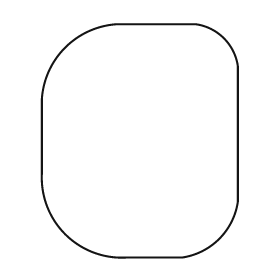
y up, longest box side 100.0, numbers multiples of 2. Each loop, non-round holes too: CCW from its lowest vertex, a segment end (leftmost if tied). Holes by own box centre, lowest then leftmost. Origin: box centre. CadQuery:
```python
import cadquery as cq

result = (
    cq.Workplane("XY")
    .moveTo(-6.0, -50.0)
    .lineTo(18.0, -50.0)
    .threePointArc((34.0, -42.0), (42.0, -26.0))
    .lineTo(42.0, 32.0)
    .threePointArc((36.0, 44.0), (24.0, 50.0))
    .lineTo(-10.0, 50.0)
    .threePointArc((-32.0, 40.0), (-42.0, 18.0))
    .lineTo(-42.0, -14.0)
    .threePointArc((-32.0, -40.0), (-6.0, -50.0))
    .close()
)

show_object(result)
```